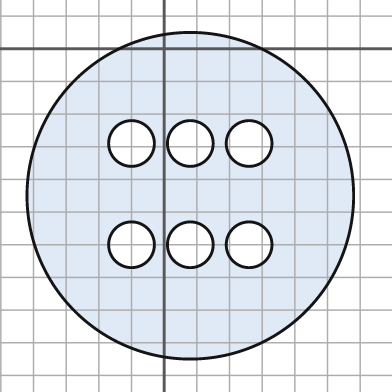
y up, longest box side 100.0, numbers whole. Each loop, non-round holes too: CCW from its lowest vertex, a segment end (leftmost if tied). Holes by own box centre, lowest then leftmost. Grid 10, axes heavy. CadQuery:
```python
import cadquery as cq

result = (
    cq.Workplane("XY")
    .moveTo(8.0, -45.0)
    .circle(50.0)
    .moveTo(-10.0, -60.0)
    .circle(7.0)
    .moveTo(8.0, -60.0)
    .circle(7.0)
    .moveTo(26.0, -60.0)
    .circle(7.0)
    .moveTo(-10.0, -29.0)
    .circle(7.0)
    .moveTo(8.0, -29.0)
    .circle(7.0)
    .moveTo(26.0, -29.0)
    .circle(7.0)
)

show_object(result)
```